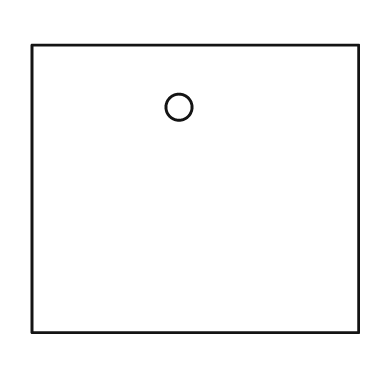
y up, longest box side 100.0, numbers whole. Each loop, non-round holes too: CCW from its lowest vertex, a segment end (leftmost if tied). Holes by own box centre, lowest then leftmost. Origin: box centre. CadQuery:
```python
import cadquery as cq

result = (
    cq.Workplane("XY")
    .moveTo(-50.0, -44.0)
    .lineTo(50.0, -44.0)
    .lineTo(50.0, 44.0)
    .lineTo(-50.0, 44.0)
    .close()
    .moveTo(-5.0, 25.0)
    .circle(4.0)
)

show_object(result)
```